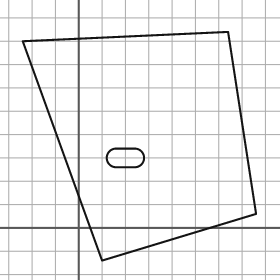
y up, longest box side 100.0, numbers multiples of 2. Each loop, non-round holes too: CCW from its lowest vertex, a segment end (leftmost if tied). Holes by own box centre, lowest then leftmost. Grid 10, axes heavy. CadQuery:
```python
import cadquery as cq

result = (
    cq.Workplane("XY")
    .moveTo(10.0, -14.0)
    .lineTo(76.0, 6.0)
    .lineTo(64.0, 84.0)
    .lineTo(-24.0, 80.0)
    .close()
    .moveTo(16.0, 26.0)
    .lineTo(24.0, 26.0)
    .threePointArc((28.0, 30.0), (24.0, 34.0))
    .lineTo(16.0, 34.0)
    .threePointArc((12.0, 30.0), (16.0, 26.0))
    .close()
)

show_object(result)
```